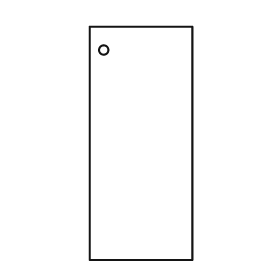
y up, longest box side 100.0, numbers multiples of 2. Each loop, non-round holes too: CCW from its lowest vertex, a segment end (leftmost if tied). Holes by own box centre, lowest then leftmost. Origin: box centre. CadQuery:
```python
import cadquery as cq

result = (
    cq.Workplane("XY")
    .moveTo(-22.0, -50.0)
    .lineTo(22.0, -50.0)
    .lineTo(22.0, 50.0)
    .lineTo(-22.0, 50.0)
    .close()
    .moveTo(-16.0, 40.0)
    .circle(2.0)
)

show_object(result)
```